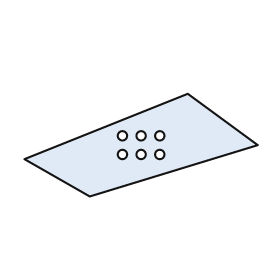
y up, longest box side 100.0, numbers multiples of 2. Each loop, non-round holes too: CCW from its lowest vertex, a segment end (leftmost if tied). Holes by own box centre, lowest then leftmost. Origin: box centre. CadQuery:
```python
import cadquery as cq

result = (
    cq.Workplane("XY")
    .moveTo(-22.0, -22.0)
    .lineTo(50.0, 0.0)
    .lineTo(20.0, 22.0)
    .lineTo(-50.0, -6.0)
    .close()
    .moveTo(-8.0, -4.0)
    .circle(2.0)
    .moveTo(0.0, -4.0)
    .circle(2.0)
    .moveTo(8.0, -4.0)
    .circle(2.0)
    .moveTo(-8.0, 4.0)
    .circle(2.0)
    .moveTo(0.0, 4.0)
    .circle(2.0)
    .moveTo(8.0, 4.0)
    .circle(2.0)
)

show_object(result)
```